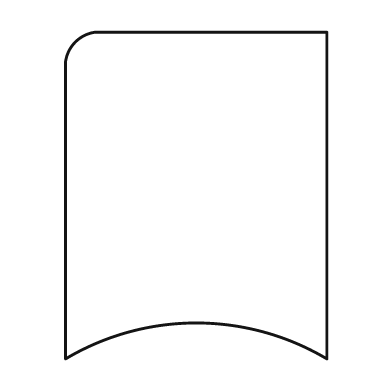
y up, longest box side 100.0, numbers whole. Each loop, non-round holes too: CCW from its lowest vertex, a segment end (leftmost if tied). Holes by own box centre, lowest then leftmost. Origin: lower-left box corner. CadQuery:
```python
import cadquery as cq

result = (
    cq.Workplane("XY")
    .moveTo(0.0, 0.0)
    .threePointArc((40.0, 11.0), (80.0, 0.0))
    .lineTo(80.0, 100.0)
    .lineTo(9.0, 100.0)
    .threePointArc((3.0, 97.0), (0.0, 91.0))
    .close()
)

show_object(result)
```